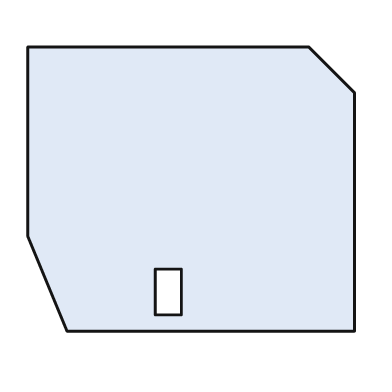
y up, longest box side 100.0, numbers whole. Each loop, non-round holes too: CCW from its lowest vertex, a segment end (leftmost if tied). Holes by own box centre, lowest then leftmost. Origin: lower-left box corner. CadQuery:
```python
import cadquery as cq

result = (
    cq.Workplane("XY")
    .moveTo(12.0, 0.0)
    .lineTo(100.0, 0.0)
    .lineTo(100.0, 73.0)
    .lineTo(86.0, 87.0)
    .lineTo(0.0, 87.0)
    .lineTo(0.0, 29.0)
    .close()
    .moveTo(39.0, 5.0)
    .lineTo(47.0, 5.0)
    .lineTo(47.0, 19.0)
    .lineTo(39.0, 19.0)
    .close()
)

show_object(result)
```